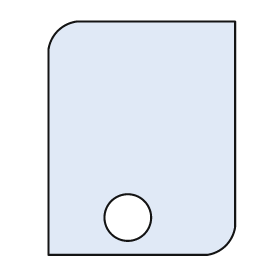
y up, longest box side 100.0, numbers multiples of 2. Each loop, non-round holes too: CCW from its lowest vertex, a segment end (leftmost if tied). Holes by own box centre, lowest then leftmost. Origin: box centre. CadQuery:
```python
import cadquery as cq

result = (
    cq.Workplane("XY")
    .moveTo(-40.0, -50.0)
    .lineTo(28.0, -50.0)
    .threePointArc((36.0, -46.0), (40.0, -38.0))
    .lineTo(40.0, 50.0)
    .lineTo(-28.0, 50.0)
    .threePointArc((-36.0, 46.0), (-40.0, 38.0))
    .close()
    .moveTo(-6.0, -34.0)
    .circle(10.0)
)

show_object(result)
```